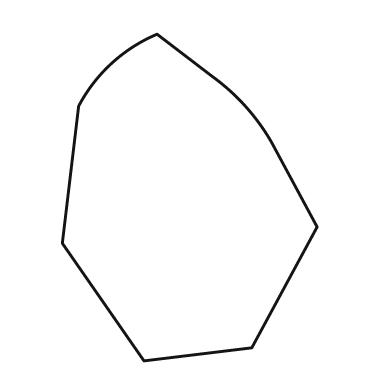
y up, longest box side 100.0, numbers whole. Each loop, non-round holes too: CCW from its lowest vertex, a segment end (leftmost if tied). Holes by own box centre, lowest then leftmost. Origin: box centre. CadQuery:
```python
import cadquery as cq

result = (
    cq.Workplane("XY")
    .moveTo(-14.0, -50.0)
    .lineTo(19.0, -46.0)
    .lineTo(39.0, -9.0)
    .lineTo(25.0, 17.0)
    .threePointArc((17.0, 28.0), (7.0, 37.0))
    .lineTo(-10.0, 50.0)
    .threePointArc((-24.0, 41.0), (-34.0, 28.0))
    .lineTo(-39.0, -14.0)
    .close()
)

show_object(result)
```